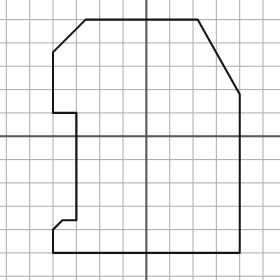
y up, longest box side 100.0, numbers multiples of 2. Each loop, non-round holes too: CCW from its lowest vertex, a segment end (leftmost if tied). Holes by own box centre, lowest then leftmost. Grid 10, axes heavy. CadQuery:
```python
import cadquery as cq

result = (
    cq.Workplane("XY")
    .moveTo(-40.0, -50.0)
    .lineTo(40.0, -50.0)
    .lineTo(40.0, 18.0)
    .lineTo(22.0, 50.0)
    .lineTo(-26.0, 50.0)
    .lineTo(-40.0, 36.0)
    .lineTo(-40.0, 10.0)
    .lineTo(-30.0, 10.0)
    .lineTo(-30.0, -36.0)
    .lineTo(-36.0, -36.0)
    .lineTo(-40.0, -40.0)
    .close()
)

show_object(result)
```